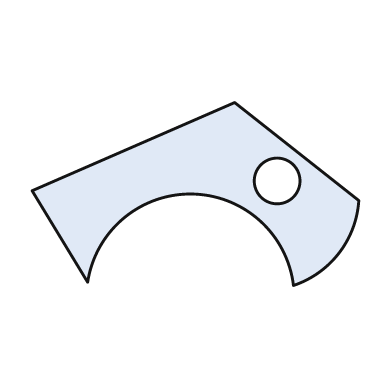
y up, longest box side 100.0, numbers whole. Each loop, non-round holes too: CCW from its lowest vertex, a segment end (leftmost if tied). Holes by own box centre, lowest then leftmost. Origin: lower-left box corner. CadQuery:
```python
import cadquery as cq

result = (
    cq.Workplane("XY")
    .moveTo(80.0, 0.0)
    .threePointArc((94.0, 10.0), (100.0, 26.0))
    .lineTo(62.0, 56.0)
    .lineTo(0.0, 29.0)
    .lineTo(17.0, 1.0)
    .threePointArc((49.0, 28.0), (80.0, 0.0))
    .close()
    .moveTo(75.0, 32.0)
    .circle(7.0)
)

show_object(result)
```